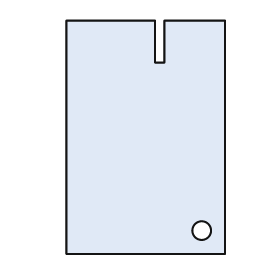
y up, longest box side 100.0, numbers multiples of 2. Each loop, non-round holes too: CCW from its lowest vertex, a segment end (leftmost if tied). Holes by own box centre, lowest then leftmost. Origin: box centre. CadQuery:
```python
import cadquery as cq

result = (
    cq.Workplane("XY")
    .moveTo(-34.0, -50.0)
    .lineTo(34.0, -50.0)
    .lineTo(34.0, 50.0)
    .lineTo(8.0, 50.0)
    .lineTo(8.0, 32.0)
    .lineTo(4.0, 32.0)
    .lineTo(4.0, 50.0)
    .lineTo(-34.0, 50.0)
    .close()
    .moveTo(24.0, -40.0)
    .circle(4.0)
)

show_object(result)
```